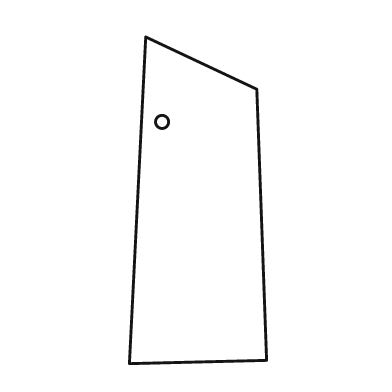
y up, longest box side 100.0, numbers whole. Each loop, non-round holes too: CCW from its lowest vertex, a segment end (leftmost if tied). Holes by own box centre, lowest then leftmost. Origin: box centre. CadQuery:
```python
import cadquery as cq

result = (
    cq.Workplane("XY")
    .moveTo(-21.0, -50.0)
    .lineTo(21.0, -49.0)
    .lineTo(18.0, 34.0)
    .lineTo(-16.0, 50.0)
    .close()
    .moveTo(-11.0, 24.0)
    .circle(2.0)
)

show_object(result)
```